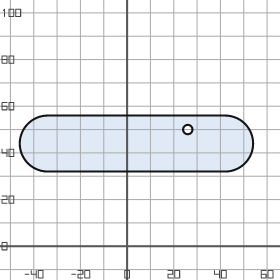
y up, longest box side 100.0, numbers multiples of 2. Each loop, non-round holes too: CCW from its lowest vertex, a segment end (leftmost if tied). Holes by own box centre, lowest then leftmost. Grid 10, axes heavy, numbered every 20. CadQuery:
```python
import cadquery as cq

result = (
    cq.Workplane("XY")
    .moveTo(-34.0, 32.0)
    .lineTo(42.0, 32.0)
    .threePointArc((54.0, 44.0), (42.0, 56.0))
    .lineTo(-34.0, 56.0)
    .threePointArc((-46.0, 44.0), (-34.0, 32.0))
    .close()
    .moveTo(26.0, 50.0)
    .circle(2.0)
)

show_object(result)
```